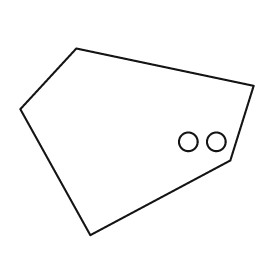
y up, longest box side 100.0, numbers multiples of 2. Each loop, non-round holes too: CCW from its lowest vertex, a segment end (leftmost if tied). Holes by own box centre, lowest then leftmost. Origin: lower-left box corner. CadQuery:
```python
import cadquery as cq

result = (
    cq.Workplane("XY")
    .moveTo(30.0, 0.0)
    .lineTo(90.0, 32.0)
    .lineTo(100.0, 64.0)
    .lineTo(24.0, 80.0)
    .lineTo(0.0, 54.0)
    .close()
    .moveTo(72.0, 40.0)
    .circle(4.0)
    .moveTo(84.0, 40.0)
    .circle(4.0)
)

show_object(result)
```